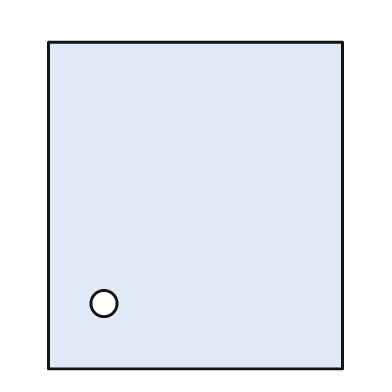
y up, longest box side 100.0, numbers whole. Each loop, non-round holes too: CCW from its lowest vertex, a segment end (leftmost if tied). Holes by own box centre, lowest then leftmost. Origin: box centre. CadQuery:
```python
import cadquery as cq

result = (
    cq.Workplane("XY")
    .moveTo(-45.0, -50.0)
    .lineTo(45.0, -50.0)
    .lineTo(45.0, 50.0)
    .lineTo(-45.0, 50.0)
    .close()
    .moveTo(-28.0, -30.0)
    .circle(4.0)
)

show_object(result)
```